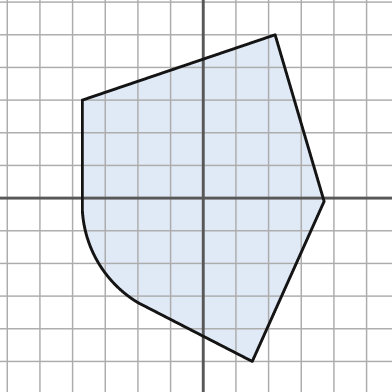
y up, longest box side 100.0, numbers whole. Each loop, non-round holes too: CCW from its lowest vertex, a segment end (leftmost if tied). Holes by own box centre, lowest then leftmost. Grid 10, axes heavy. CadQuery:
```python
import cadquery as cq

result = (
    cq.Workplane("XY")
    .moveTo(15.0, -50.0)
    .lineTo(37.0, -1.0)
    .lineTo(22.0, 50.0)
    .lineTo(-37.0, 30.0)
    .lineTo(-37.0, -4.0)
    .threePointArc((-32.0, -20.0), (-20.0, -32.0))
    .close()
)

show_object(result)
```